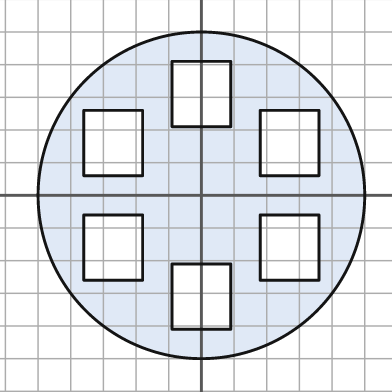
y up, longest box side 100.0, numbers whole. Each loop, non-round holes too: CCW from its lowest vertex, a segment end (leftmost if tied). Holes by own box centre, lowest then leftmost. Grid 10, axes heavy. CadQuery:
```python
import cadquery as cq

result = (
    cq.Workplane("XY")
    .moveTo(0.0, 0.0)
    .circle(50.0)
    .moveTo(-9.0, -41.0)
    .lineTo(9.0, -41.0)
    .lineTo(9.0, -21.0)
    .lineTo(-9.0, -21.0)
    .close()
    .moveTo(-36.0, -26.0)
    .lineTo(-18.0, -26.0)
    .lineTo(-18.0, -6.0)
    .lineTo(-36.0, -6.0)
    .close()
    .moveTo(18.0, -26.0)
    .lineTo(36.0, -26.0)
    .lineTo(36.0, -6.0)
    .lineTo(18.0, -6.0)
    .close()
    .moveTo(-36.0, 6.0)
    .lineTo(-18.0, 6.0)
    .lineTo(-18.0, 26.0)
    .lineTo(-36.0, 26.0)
    .close()
    .moveTo(18.0, 6.0)
    .lineTo(36.0, 6.0)
    .lineTo(36.0, 26.0)
    .lineTo(18.0, 26.0)
    .close()
    .moveTo(-9.0, 21.0)
    .lineTo(9.0, 21.0)
    .lineTo(9.0, 41.0)
    .lineTo(-9.0, 41.0)
    .close()
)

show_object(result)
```